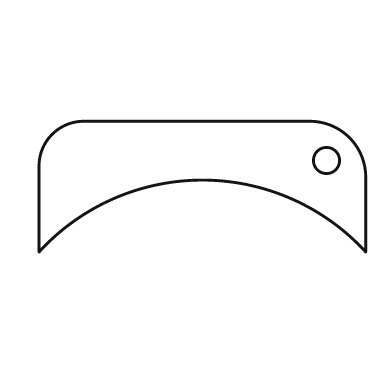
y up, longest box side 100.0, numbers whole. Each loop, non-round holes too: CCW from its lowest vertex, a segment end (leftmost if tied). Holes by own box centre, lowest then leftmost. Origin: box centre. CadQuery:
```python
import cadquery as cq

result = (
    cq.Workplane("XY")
    .moveTo(-50.0, -20.0)
    .threePointArc((0.0, 2.0), (50.0, -20.0))
    .lineTo(50.0, 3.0)
    .threePointArc((45.0, 15.0), (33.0, 20.0))
    .lineTo(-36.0, 20.0)
    .threePointArc((-46.0, 16.0), (-50.0, 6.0))
    .close()
    .moveTo(38.0, 8.0)
    .circle(4.0)
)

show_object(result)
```